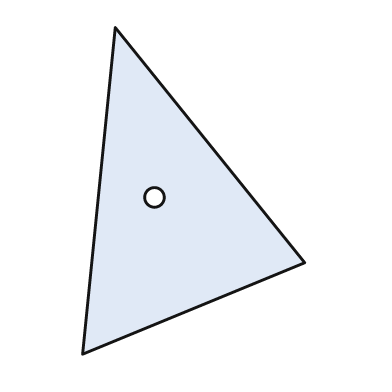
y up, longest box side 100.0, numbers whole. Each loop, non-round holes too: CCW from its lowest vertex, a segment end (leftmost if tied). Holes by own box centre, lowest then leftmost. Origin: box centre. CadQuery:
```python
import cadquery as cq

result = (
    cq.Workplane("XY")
    .moveTo(-34.0, -50.0)
    .lineTo(34.0, -22.0)
    .lineTo(-24.0, 50.0)
    .close()
    .moveTo(-12.0, -2.0)
    .circle(3.0)
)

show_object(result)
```